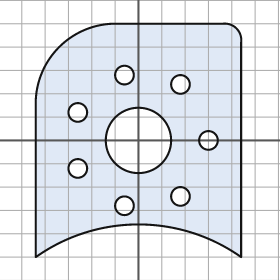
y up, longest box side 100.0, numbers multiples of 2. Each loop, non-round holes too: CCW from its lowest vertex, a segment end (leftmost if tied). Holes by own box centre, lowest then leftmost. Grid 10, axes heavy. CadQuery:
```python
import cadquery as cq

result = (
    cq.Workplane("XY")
    .moveTo(-44.0, -50.0)
    .threePointArc((0.0, -36.0), (44.0, -50.0))
    .lineTo(44.0, 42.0)
    .threePointArc((42.0, 48.0), (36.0, 50.0))
    .lineTo(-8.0, 50.0)
    .threePointArc((-34.0, 40.0), (-44.0, 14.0))
    .close()
    .moveTo(-6.0, -28.0)
    .circle(4.0)
    .moveTo(18.0, -24.0)
    .circle(4.0)
    .moveTo(-26.0, -12.0)
    .circle(4.0)
    .moveTo(0.0, 0.0)
    .circle(14.0)
    .moveTo(30.0, 0.0)
    .circle(4.0)
    .moveTo(-26.0, 12.0)
    .circle(4.0)
    .moveTo(18.0, 24.0)
    .circle(4.0)
    .moveTo(-6.0, 28.0)
    .circle(4.0)
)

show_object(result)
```